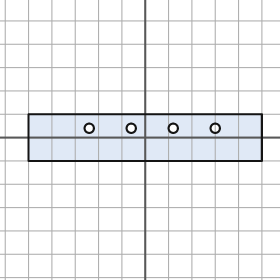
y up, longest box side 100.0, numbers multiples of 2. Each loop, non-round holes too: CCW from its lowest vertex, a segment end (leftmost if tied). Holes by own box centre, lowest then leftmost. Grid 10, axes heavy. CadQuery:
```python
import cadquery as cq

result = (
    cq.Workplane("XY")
    .moveTo(-50.0, -10.0)
    .lineTo(50.0, -10.0)
    .lineTo(50.0, 10.0)
    .lineTo(-50.0, 10.0)
    .close()
    .moveTo(-24.0, 4.0)
    .circle(2.0)
    .moveTo(-6.0, 4.0)
    .circle(2.0)
    .moveTo(12.0, 4.0)
    .circle(2.0)
    .moveTo(30.0, 4.0)
    .circle(2.0)
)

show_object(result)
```